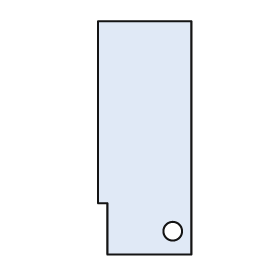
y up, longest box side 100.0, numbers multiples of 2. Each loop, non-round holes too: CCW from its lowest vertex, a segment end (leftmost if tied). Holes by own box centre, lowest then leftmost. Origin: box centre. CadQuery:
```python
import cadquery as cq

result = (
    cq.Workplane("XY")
    .moveTo(-16.0, -50.0)
    .lineTo(20.0, -50.0)
    .lineTo(20.0, 50.0)
    .lineTo(-20.0, 50.0)
    .lineTo(-20.0, -28.0)
    .lineTo(-16.0, -28.0)
    .close()
    .moveTo(12.0, -40.0)
    .circle(4.0)
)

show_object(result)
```